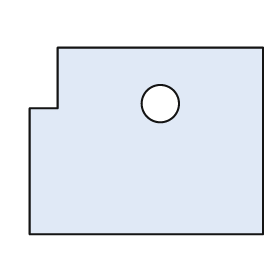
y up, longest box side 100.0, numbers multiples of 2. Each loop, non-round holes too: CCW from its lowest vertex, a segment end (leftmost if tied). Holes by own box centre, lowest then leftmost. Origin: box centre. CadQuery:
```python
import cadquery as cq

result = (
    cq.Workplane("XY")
    .moveTo(-50.0, -40.0)
    .lineTo(50.0, -40.0)
    .lineTo(50.0, 40.0)
    .lineTo(-38.0, 40.0)
    .lineTo(-38.0, 14.0)
    .lineTo(-50.0, 14.0)
    .close()
    .moveTo(6.0, 16.0)
    .circle(8.0)
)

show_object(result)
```